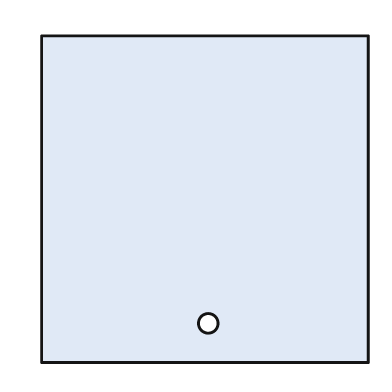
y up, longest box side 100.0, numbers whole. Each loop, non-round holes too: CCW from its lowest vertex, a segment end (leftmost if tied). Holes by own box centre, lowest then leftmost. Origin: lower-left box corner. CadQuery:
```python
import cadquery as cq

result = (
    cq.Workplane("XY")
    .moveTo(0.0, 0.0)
    .lineTo(100.0, 0.0)
    .lineTo(100.0, 100.0)
    .lineTo(0.0, 100.0)
    .close()
    .moveTo(51.0, 12.0)
    .circle(3.0)
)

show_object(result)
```